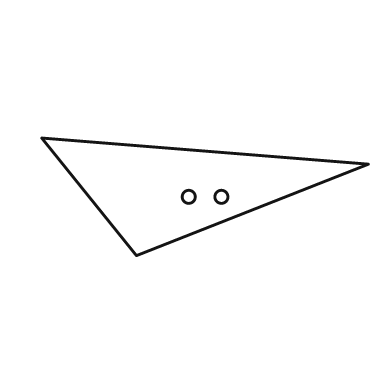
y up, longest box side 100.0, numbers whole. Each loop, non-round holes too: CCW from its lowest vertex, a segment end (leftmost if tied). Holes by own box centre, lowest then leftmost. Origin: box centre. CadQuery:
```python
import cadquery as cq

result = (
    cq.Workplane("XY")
    .moveTo(-21.0, -18.0)
    .lineTo(50.0, 10.0)
    .lineTo(-50.0, 18.0)
    .close()
    .moveTo(-5.0, 0.0)
    .circle(2.0)
    .moveTo(5.0, 0.0)
    .circle(2.0)
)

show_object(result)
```